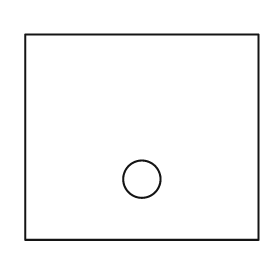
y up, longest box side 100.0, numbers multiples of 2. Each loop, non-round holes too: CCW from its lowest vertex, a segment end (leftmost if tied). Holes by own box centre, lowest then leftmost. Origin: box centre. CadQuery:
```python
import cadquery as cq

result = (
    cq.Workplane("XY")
    .moveTo(-50.0, -44.0)
    .lineTo(50.0, -44.0)
    .lineTo(50.0, 44.0)
    .lineTo(-50.0, 44.0)
    .close()
    .moveTo(0.0, -18.0)
    .circle(8.0)
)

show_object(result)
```